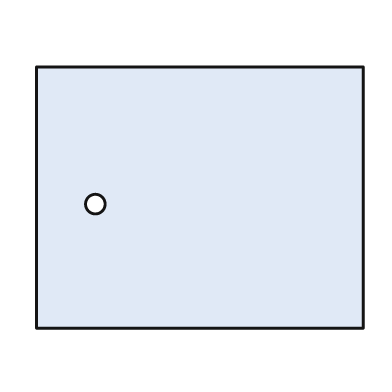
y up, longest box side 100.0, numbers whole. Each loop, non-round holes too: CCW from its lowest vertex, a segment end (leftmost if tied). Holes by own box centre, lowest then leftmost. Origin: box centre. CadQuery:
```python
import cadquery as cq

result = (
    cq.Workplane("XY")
    .moveTo(-50.0, -40.0)
    .lineTo(50.0, -40.0)
    .lineTo(50.0, 40.0)
    .lineTo(-50.0, 40.0)
    .close()
    .moveTo(-32.0, -2.0)
    .circle(3.0)
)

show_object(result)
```